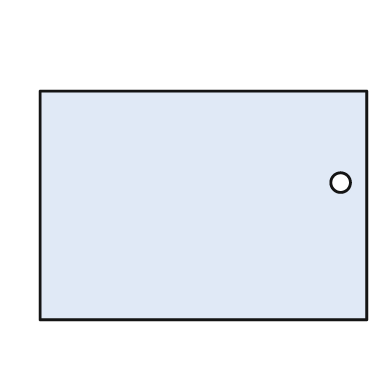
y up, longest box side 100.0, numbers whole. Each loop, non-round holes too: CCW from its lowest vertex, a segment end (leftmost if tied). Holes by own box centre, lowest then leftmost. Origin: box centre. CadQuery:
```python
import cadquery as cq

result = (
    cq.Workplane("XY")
    .moveTo(-50.0, -35.0)
    .lineTo(50.0, -35.0)
    .lineTo(50.0, 35.0)
    .lineTo(-50.0, 35.0)
    .close()
    .moveTo(42.0, 7.0)
    .circle(3.0)
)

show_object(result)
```